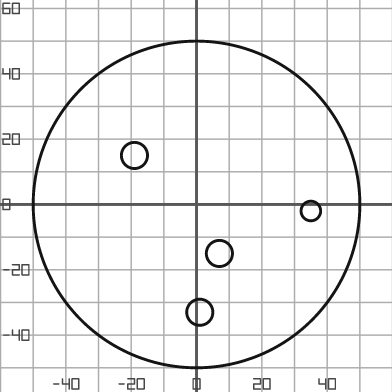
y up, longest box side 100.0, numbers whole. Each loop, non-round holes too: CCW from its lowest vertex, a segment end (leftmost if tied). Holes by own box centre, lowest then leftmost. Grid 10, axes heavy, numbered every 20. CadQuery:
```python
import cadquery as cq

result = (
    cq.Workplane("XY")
    .moveTo(0.0, 0.0)
    .circle(50.0)
    .moveTo(1.0, -33.0)
    .circle(4.0)
    .moveTo(7.0, -15.0)
    .circle(4.0)
    .moveTo(35.0, -2.0)
    .circle(3.0)
    .moveTo(-19.0, 15.0)
    .circle(4.0)
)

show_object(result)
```